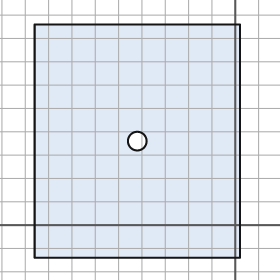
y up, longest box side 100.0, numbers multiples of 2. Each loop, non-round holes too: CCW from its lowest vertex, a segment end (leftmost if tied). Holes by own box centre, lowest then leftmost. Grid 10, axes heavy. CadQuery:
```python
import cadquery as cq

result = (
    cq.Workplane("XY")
    .moveTo(-86.0, -14.0)
    .lineTo(2.0, -14.0)
    .lineTo(2.0, 86.0)
    .lineTo(-86.0, 86.0)
    .close()
    .moveTo(-42.0, 36.0)
    .circle(4.0)
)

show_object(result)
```